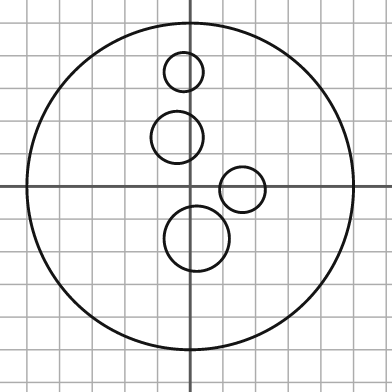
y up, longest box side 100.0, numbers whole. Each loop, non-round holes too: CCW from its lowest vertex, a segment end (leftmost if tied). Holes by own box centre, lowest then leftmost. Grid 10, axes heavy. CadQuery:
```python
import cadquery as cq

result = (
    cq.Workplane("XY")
    .moveTo(0.0, 0.0)
    .circle(50.0)
    .moveTo(2.0, -16.0)
    .circle(10.0)
    .moveTo(16.0, -1.0)
    .circle(7.0)
    .moveTo(-4.0, 15.0)
    .circle(8.0)
    .moveTo(-2.0, 35.0)
    .circle(6.0)
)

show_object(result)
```